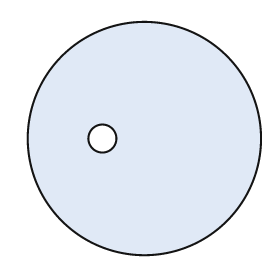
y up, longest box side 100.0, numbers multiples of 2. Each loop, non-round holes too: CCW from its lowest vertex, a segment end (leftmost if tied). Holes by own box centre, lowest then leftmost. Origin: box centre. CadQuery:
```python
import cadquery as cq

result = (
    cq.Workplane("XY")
    .moveTo(0.0, 0.0)
    .circle(50.0)
    .moveTo(-18.0, 0.0)
    .circle(6.0)
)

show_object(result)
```